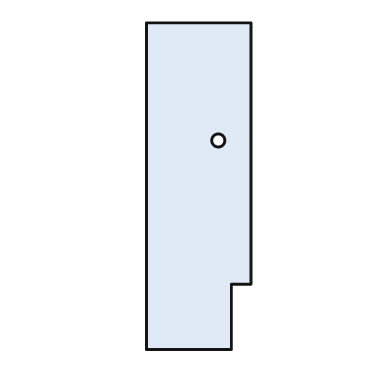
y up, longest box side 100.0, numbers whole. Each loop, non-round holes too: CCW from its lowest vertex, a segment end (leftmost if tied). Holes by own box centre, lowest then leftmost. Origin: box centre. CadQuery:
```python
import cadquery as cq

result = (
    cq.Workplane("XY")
    .moveTo(-16.0, -50.0)
    .lineTo(10.0, -50.0)
    .lineTo(10.0, -30.0)
    .lineTo(16.0, -30.0)
    .lineTo(16.0, 50.0)
    .lineTo(-16.0, 50.0)
    .close()
    .moveTo(6.0, 14.0)
    .circle(2.0)
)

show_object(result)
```